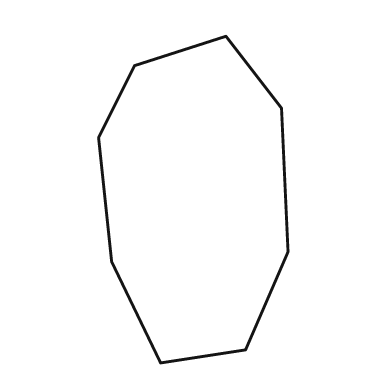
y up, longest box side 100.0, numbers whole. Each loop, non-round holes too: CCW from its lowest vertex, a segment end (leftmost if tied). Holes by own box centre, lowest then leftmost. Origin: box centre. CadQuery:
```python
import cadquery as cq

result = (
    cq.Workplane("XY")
    .moveTo(-10.0, -50.0)
    .lineTo(16.0, -46.0)
    .lineTo(29.0, -16.0)
    .lineTo(27.0, 28.0)
    .lineTo(10.0, 50.0)
    .lineTo(-18.0, 41.0)
    .lineTo(-29.0, 19.0)
    .lineTo(-25.0, -19.0)
    .close()
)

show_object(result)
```